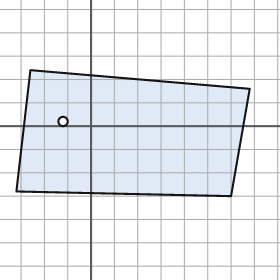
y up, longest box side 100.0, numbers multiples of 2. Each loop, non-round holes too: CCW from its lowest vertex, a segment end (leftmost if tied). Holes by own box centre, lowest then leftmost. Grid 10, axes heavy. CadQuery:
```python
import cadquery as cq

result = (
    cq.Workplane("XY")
    .moveTo(60.0, -30.0)
    .lineTo(68.0, 16.0)
    .lineTo(-26.0, 24.0)
    .lineTo(-32.0, -28.0)
    .close()
    .moveTo(-12.0, 2.0)
    .circle(2.0)
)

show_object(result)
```